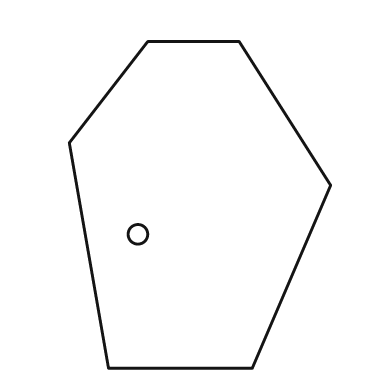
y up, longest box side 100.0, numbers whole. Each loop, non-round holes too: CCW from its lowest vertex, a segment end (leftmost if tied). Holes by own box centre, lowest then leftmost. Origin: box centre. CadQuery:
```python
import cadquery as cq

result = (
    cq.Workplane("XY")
    .moveTo(-28.0, -50.0)
    .lineTo(16.0, -50.0)
    .lineTo(40.0, 6.0)
    .lineTo(12.0, 50.0)
    .lineTo(-16.0, 50.0)
    .lineTo(-40.0, 19.0)
    .close()
    .moveTo(-19.0, -9.0)
    .circle(3.0)
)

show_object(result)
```